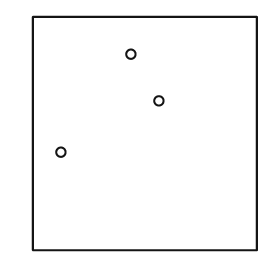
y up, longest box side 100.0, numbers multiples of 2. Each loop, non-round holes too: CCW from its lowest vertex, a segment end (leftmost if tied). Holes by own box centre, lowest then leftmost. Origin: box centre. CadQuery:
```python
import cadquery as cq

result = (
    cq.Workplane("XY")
    .moveTo(-48.0, -50.0)
    .lineTo(48.0, -50.0)
    .lineTo(48.0, 50.0)
    .lineTo(-48.0, 50.0)
    .close()
    .moveTo(-36.0, -8.0)
    .circle(2.0)
    .moveTo(6.0, 14.0)
    .circle(2.0)
    .moveTo(-6.0, 34.0)
    .circle(2.0)
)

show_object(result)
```